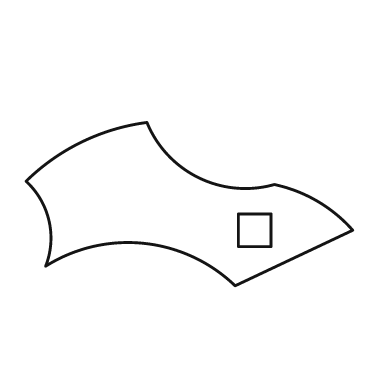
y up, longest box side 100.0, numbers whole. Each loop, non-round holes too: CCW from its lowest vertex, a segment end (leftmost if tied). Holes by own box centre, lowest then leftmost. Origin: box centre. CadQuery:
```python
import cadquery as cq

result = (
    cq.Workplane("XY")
    .moveTo(14.0, -25.0)
    .lineTo(50.0, -8.0)
    .threePointArc((39.0, 1.0), (26.0, 6.0))
    .threePointArc((3.0, 8.0), (-13.0, 25.0))
    .threePointArc((-33.0, 19.0), (-50.0, 7.0))
    .threePointArc((-43.0, -5.0), (-44.0, -19.0))
    .threePointArc((-14.0, -12.0), (14.0, -25.0))
    .close()
    .moveTo(15.0, -13.0)
    .lineTo(25.0, -13.0)
    .lineTo(25.0, -3.0)
    .lineTo(15.0, -3.0)
    .close()
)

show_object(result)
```